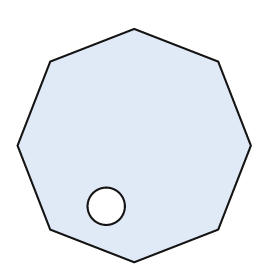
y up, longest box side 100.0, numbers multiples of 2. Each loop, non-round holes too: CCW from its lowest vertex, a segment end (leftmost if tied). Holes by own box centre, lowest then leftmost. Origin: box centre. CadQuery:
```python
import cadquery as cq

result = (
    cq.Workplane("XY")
    .moveTo(0.0, -50.0)
    .lineTo(36.0, -36.0)
    .lineTo(50.0, 0.0)
    .lineTo(36.0, 36.0)
    .lineTo(0.0, 50.0)
    .lineTo(-36.0, 36.0)
    .lineTo(-50.0, 0.0)
    .lineTo(-36.0, -36.0)
    .close()
    .moveTo(-12.0, -26.0)
    .circle(8.0)
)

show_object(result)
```